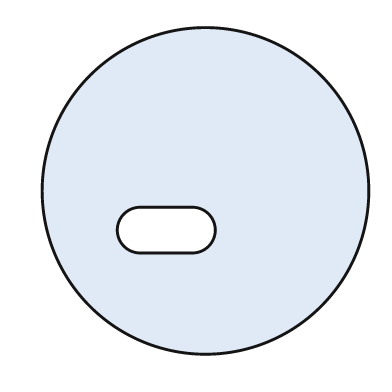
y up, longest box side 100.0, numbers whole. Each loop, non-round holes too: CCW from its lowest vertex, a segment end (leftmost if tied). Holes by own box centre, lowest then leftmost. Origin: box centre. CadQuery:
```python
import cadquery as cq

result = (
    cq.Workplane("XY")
    .moveTo(0.0, 0.0)
    .circle(50.0)
    .moveTo(-20.0, -19.0)
    .lineTo(-4.0, -19.0)
    .threePointArc((3.0, -12.0), (-4.0, -5.0))
    .lineTo(-20.0, -5.0)
    .threePointArc((-27.0, -12.0), (-20.0, -19.0))
    .close()
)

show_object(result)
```